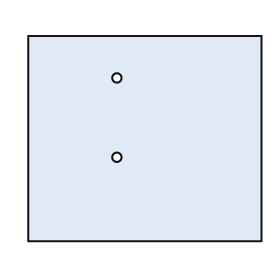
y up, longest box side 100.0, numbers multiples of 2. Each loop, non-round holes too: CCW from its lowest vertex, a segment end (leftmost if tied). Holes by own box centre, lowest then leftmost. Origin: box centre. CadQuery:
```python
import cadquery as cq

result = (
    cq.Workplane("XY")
    .moveTo(-50.0, -44.0)
    .lineTo(50.0, -44.0)
    .lineTo(50.0, 44.0)
    .lineTo(-50.0, 44.0)
    .close()
    .moveTo(-12.0, -8.0)
    .circle(2.0)
    .moveTo(-12.0, 26.0)
    .circle(2.0)
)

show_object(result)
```